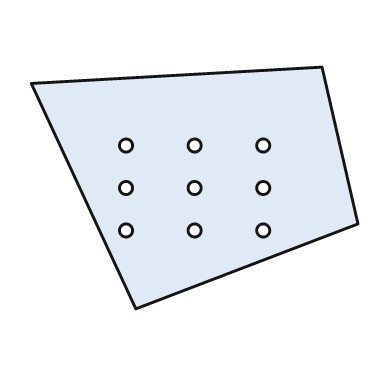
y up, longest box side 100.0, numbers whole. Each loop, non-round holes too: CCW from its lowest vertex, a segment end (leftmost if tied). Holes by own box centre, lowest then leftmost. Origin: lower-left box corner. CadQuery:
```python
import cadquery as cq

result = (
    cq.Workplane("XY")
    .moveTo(32.0, 0.0)
    .lineTo(100.0, 26.0)
    .lineTo(89.0, 74.0)
    .lineTo(0.0, 69.0)
    .close()
    .moveTo(29.0, 24.0)
    .circle(2.0)
    .moveTo(50.0, 24.0)
    .circle(2.0)
    .moveTo(71.0, 24.0)
    .circle(2.0)
    .moveTo(29.0, 37.0)
    .circle(2.0)
    .moveTo(50.0, 37.0)
    .circle(2.0)
    .moveTo(71.0, 37.0)
    .circle(2.0)
    .moveTo(29.0, 50.0)
    .circle(2.0)
    .moveTo(50.0, 50.0)
    .circle(2.0)
    .moveTo(71.0, 50.0)
    .circle(2.0)
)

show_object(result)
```